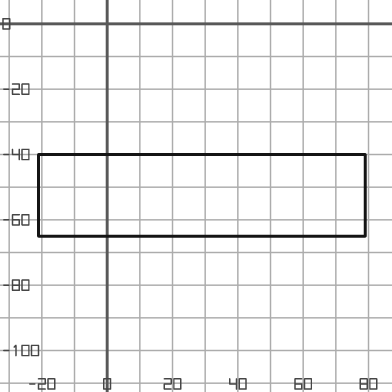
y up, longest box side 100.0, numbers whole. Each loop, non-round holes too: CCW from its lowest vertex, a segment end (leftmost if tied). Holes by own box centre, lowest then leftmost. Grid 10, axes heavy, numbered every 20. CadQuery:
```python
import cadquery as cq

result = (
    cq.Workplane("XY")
    .moveTo(-21.0, -65.0)
    .lineTo(79.0, -65.0)
    .lineTo(79.0, -40.0)
    .lineTo(-21.0, -40.0)
    .close()
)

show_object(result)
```